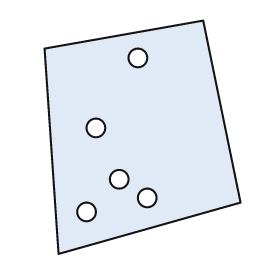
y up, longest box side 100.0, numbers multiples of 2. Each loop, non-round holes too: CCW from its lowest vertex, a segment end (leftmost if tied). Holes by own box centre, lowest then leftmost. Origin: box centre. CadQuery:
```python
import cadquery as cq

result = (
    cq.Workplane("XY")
    .moveTo(-36.0, -50.0)
    .lineTo(42.0, -28.0)
    .lineTo(26.0, 50.0)
    .lineTo(-42.0, 38.0)
    .close()
    .moveTo(-24.0, -32.0)
    .circle(4.0)
    .moveTo(2.0, -26.0)
    .circle(4.0)
    .moveTo(-10.0, -18.0)
    .circle(4.0)
    .moveTo(-20.0, 4.0)
    .circle(4.0)
    .moveTo(-2.0, 34.0)
    .circle(4.0)
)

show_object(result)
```